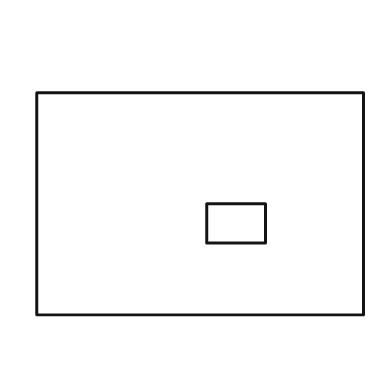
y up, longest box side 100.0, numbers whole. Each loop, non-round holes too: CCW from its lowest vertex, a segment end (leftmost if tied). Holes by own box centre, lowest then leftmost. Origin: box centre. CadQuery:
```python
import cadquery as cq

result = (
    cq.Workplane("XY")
    .moveTo(-50.0, -34.0)
    .lineTo(50.0, -34.0)
    .lineTo(50.0, 34.0)
    .lineTo(-50.0, 34.0)
    .close()
    .moveTo(2.0, -12.0)
    .lineTo(20.0, -12.0)
    .lineTo(20.0, 0.0)
    .lineTo(2.0, 0.0)
    .close()
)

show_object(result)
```